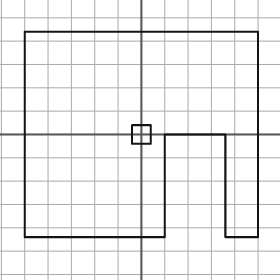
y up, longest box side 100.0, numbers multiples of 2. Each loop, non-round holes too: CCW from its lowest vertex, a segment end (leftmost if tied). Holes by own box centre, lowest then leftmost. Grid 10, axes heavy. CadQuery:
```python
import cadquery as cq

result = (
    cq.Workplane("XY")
    .moveTo(-50.0, -44.0)
    .lineTo(10.0, -44.0)
    .lineTo(10.0, 0.0)
    .lineTo(36.0, 0.0)
    .lineTo(36.0, -44.0)
    .lineTo(50.0, -44.0)
    .lineTo(50.0, 44.0)
    .lineTo(-50.0, 44.0)
    .close()
    .moveTo(-4.0, -4.0)
    .lineTo(4.0, -4.0)
    .lineTo(4.0, 4.0)
    .lineTo(-4.0, 4.0)
    .close()
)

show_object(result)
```